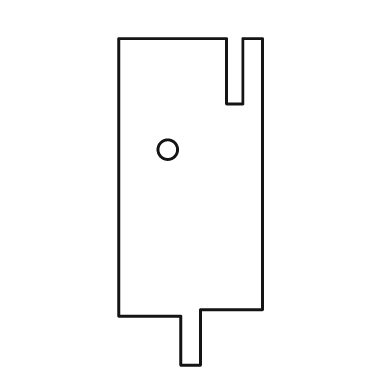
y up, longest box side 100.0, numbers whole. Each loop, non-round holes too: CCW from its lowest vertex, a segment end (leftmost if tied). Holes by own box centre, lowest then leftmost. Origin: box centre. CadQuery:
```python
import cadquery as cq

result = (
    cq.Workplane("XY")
    .moveTo(-3.0, -50.0)
    .lineTo(3.0, -50.0)
    .lineTo(3.0, -33.0)
    .lineTo(22.0, -33.0)
    .lineTo(22.0, 50.0)
    .lineTo(16.0, 50.0)
    .lineTo(16.0, 30.0)
    .lineTo(11.0, 30.0)
    .lineTo(11.0, 50.0)
    .lineTo(-22.0, 50.0)
    .lineTo(-22.0, -35.0)
    .lineTo(-3.0, -35.0)
    .close()
    .moveTo(-7.0, 16.0)
    .circle(3.0)
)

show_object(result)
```